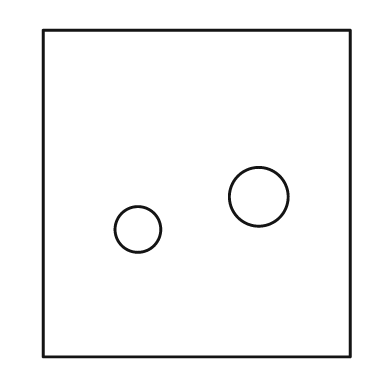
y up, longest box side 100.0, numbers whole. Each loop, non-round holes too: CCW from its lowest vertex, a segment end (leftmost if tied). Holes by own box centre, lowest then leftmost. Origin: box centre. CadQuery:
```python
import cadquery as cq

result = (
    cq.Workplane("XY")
    .moveTo(-47.0, -50.0)
    .lineTo(47.0, -50.0)
    .lineTo(47.0, 50.0)
    .lineTo(-47.0, 50.0)
    .close()
    .moveTo(-18.0, -11.0)
    .circle(7.0)
    .moveTo(19.0, -1.0)
    .circle(9.0)
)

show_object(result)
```